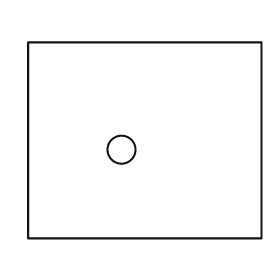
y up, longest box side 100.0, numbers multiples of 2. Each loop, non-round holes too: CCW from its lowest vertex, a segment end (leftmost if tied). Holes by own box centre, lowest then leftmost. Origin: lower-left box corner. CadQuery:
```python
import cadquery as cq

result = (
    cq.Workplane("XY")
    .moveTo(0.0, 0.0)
    .lineTo(100.0, 0.0)
    .lineTo(100.0, 84.0)
    .lineTo(0.0, 84.0)
    .close()
    .moveTo(40.0, 38.0)
    .circle(6.0)
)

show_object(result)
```